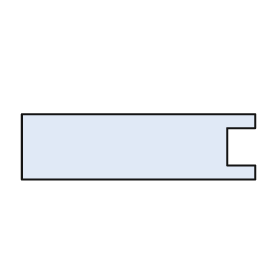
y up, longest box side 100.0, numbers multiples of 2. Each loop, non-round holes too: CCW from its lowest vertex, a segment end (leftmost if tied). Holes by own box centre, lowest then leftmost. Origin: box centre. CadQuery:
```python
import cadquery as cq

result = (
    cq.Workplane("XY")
    .moveTo(-50.0, -14.0)
    .lineTo(50.0, -14.0)
    .lineTo(50.0, -8.0)
    .lineTo(38.0, -8.0)
    .lineTo(38.0, 8.0)
    .lineTo(50.0, 8.0)
    .lineTo(50.0, 14.0)
    .lineTo(-50.0, 14.0)
    .close()
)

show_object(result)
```